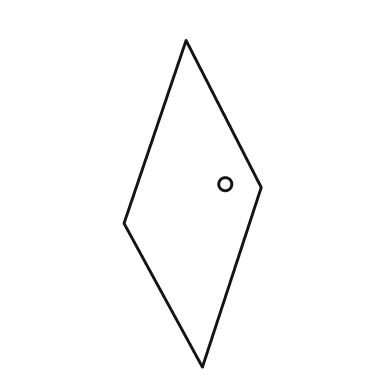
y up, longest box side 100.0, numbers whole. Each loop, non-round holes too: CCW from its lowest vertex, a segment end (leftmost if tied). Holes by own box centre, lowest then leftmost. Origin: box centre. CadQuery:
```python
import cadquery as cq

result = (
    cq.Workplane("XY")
    .moveTo(3.0, -50.0)
    .lineTo(21.0, 5.0)
    .lineTo(-2.0, 50.0)
    .lineTo(-21.0, -6.0)
    .close()
    .moveTo(10.0, 6.0)
    .circle(2.0)
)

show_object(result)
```